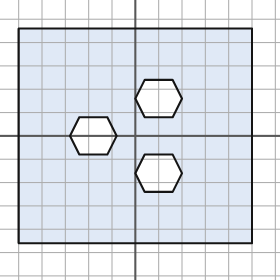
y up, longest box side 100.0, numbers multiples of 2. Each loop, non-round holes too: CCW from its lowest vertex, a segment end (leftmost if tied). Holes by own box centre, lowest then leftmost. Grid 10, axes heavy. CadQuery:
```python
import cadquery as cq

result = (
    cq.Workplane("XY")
    .moveTo(-50.0, -46.0)
    .lineTo(50.0, -46.0)
    .lineTo(50.0, 46.0)
    .lineTo(-50.0, 46.0)
    .close()
    .moveTo(4.0, -24.0)
    .lineTo(16.0, -24.0)
    .lineTo(20.0, -16.0)
    .lineTo(16.0, -8.0)
    .lineTo(4.0, -8.0)
    .lineTo(0.0, -16.0)
    .close()
    .moveTo(-24.0, -8.0)
    .lineTo(-12.0, -8.0)
    .lineTo(-8.0, 0.0)
    .lineTo(-12.0, 8.0)
    .lineTo(-24.0, 8.0)
    .lineTo(-28.0, 0.0)
    .close()
    .moveTo(4.0, 8.0)
    .lineTo(16.0, 8.0)
    .lineTo(20.0, 16.0)
    .lineTo(16.0, 24.0)
    .lineTo(4.0, 24.0)
    .lineTo(0.0, 16.0)
    .close()
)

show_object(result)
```